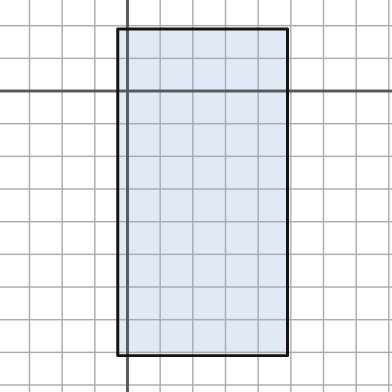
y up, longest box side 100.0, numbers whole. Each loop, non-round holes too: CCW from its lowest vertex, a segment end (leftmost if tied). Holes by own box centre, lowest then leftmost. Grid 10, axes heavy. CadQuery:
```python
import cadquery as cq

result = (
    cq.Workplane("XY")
    .moveTo(-3.0, -81.0)
    .lineTo(49.0, -81.0)
    .lineTo(49.0, 19.0)
    .lineTo(-3.0, 19.0)
    .close()
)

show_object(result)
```